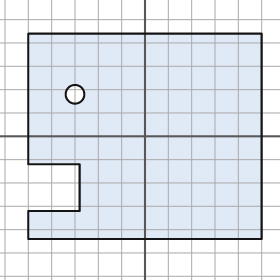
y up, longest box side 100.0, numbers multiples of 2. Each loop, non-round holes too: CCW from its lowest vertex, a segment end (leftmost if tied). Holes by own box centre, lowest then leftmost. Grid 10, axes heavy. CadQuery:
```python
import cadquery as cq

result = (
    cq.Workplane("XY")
    .moveTo(-50.0, -44.0)
    .lineTo(50.0, -44.0)
    .lineTo(50.0, 44.0)
    .lineTo(-50.0, 44.0)
    .lineTo(-50.0, -12.0)
    .lineTo(-28.0, -12.0)
    .lineTo(-28.0, -32.0)
    .lineTo(-50.0, -32.0)
    .close()
    .moveTo(-30.0, 18.0)
    .circle(4.0)
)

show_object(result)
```